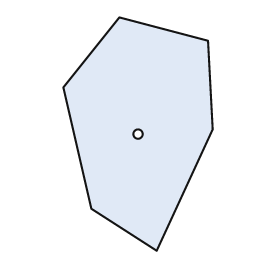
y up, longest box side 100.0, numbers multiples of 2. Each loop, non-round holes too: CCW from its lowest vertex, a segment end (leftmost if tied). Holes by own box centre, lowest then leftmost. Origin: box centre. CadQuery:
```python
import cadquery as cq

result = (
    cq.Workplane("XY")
    .moveTo(8.0, -50.0)
    .lineTo(32.0, 2.0)
    .lineTo(30.0, 40.0)
    .lineTo(-8.0, 50.0)
    .lineTo(-32.0, 20.0)
    .lineTo(-20.0, -32.0)
    .close()
    .moveTo(0.0, 0.0)
    .circle(2.0)
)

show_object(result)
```